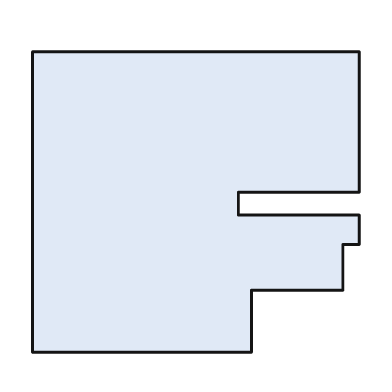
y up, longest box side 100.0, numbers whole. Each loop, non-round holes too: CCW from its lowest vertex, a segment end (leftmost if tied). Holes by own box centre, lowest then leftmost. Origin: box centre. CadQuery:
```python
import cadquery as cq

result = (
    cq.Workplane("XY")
    .moveTo(-50.0, -46.0)
    .lineTo(17.0, -46.0)
    .lineTo(17.0, -27.0)
    .lineTo(45.0, -27.0)
    .lineTo(45.0, -13.0)
    .lineTo(50.0, -13.0)
    .lineTo(50.0, -4.0)
    .lineTo(13.0, -4.0)
    .lineTo(13.0, 3.0)
    .lineTo(50.0, 3.0)
    .lineTo(50.0, 46.0)
    .lineTo(-50.0, 46.0)
    .close()
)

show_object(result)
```